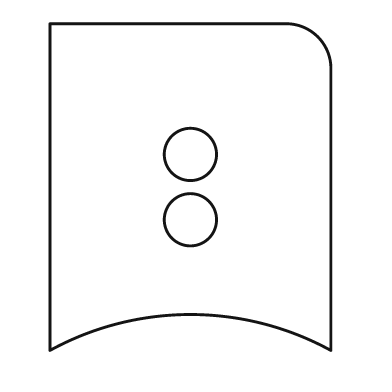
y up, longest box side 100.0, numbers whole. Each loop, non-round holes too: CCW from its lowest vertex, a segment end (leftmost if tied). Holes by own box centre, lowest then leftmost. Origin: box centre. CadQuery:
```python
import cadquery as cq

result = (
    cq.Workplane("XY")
    .moveTo(-43.0, -50.0)
    .threePointArc((0.0, -39.0), (43.0, -50.0))
    .lineTo(43.0, 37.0)
    .threePointArc((39.0, 46.0), (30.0, 50.0))
    .lineTo(-43.0, 50.0)
    .close()
    .moveTo(0.0, -10.0)
    .circle(8.0)
    .moveTo(0.0, 10.0)
    .circle(8.0)
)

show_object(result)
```